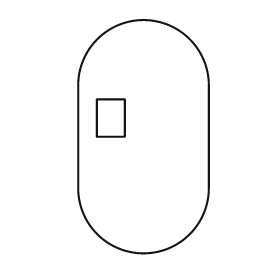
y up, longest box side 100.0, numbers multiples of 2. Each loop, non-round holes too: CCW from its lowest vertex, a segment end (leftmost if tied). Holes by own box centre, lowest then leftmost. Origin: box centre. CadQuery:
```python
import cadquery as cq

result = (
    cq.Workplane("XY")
    .moveTo(-28.0, -22.0)
    .threePointArc((0.0, -50.0), (28.0, -22.0))
    .lineTo(28.0, 22.0)
    .threePointArc((0.0, 50.0), (-28.0, 22.0))
    .close()
    .moveTo(-20.0, 0.0)
    .lineTo(-8.0, 0.0)
    .lineTo(-8.0, 16.0)
    .lineTo(-20.0, 16.0)
    .close()
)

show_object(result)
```